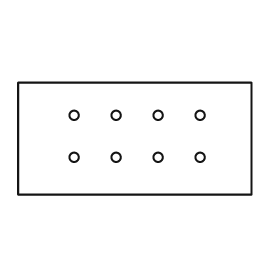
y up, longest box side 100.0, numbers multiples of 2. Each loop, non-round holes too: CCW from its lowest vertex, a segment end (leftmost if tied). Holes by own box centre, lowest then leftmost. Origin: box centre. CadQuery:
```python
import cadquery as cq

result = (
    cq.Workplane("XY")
    .moveTo(-50.0, -24.0)
    .lineTo(50.0, -24.0)
    .lineTo(50.0, 24.0)
    .lineTo(-50.0, 24.0)
    .close()
    .moveTo(-26.0, -8.0)
    .circle(2.0)
    .moveTo(-8.0, -8.0)
    .circle(2.0)
    .moveTo(10.0, -8.0)
    .circle(2.0)
    .moveTo(28.0, -8.0)
    .circle(2.0)
    .moveTo(-26.0, 10.0)
    .circle(2.0)
    .moveTo(-8.0, 10.0)
    .circle(2.0)
    .moveTo(10.0, 10.0)
    .circle(2.0)
    .moveTo(28.0, 10.0)
    .circle(2.0)
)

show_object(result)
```